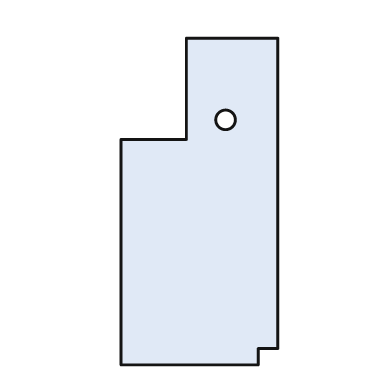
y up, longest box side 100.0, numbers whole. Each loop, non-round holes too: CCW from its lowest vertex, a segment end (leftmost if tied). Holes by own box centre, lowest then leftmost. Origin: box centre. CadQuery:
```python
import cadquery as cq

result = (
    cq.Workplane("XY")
    .moveTo(-24.0, -50.0)
    .lineTo(18.0, -50.0)
    .lineTo(18.0, -45.0)
    .lineTo(24.0, -45.0)
    .lineTo(24.0, 50.0)
    .lineTo(-4.0, 50.0)
    .lineTo(-4.0, 19.0)
    .lineTo(-24.0, 19.0)
    .close()
    .moveTo(8.0, 25.0)
    .circle(3.0)
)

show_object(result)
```